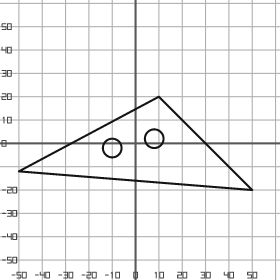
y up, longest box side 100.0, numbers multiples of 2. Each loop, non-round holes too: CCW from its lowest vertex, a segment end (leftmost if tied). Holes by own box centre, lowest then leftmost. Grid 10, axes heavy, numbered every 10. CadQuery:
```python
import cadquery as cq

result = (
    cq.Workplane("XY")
    .moveTo(50.0, -20.0)
    .lineTo(10.0, 20.0)
    .lineTo(-50.0, -12.0)
    .close()
    .moveTo(-10.0, -2.0)
    .circle(4.0)
    .moveTo(8.0, 2.0)
    .circle(4.0)
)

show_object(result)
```